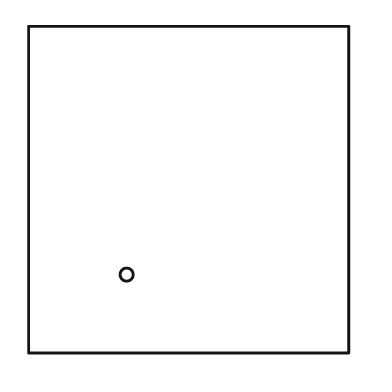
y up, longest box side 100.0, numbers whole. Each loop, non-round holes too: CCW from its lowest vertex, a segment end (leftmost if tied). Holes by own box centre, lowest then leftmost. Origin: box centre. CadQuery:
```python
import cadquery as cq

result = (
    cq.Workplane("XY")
    .moveTo(-49.0, -50.0)
    .lineTo(49.0, -50.0)
    .lineTo(49.0, 50.0)
    .lineTo(-49.0, 50.0)
    .close()
    .moveTo(-19.0, -26.0)
    .circle(2.0)
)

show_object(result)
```